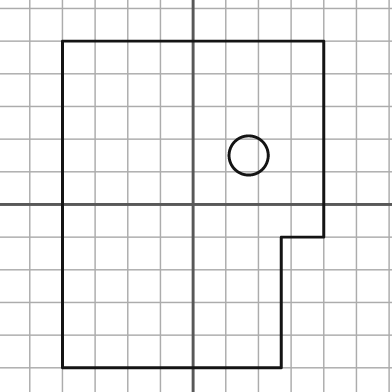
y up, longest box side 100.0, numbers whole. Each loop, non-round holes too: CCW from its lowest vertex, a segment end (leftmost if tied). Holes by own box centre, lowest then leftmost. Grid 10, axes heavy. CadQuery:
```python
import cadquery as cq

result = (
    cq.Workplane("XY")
    .moveTo(-40.0, -50.0)
    .lineTo(27.0, -50.0)
    .lineTo(27.0, -10.0)
    .lineTo(40.0, -10.0)
    .lineTo(40.0, 50.0)
    .lineTo(-40.0, 50.0)
    .close()
    .moveTo(17.0, 15.0)
    .circle(6.0)
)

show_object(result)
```